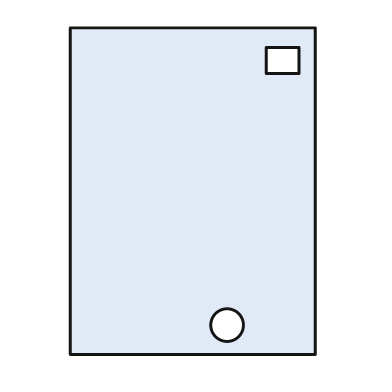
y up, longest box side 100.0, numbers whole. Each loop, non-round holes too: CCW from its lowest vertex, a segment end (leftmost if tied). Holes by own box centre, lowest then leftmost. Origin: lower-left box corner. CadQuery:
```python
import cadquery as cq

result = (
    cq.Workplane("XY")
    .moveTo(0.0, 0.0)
    .lineTo(75.0, 0.0)
    .lineTo(75.0, 100.0)
    .lineTo(0.0, 100.0)
    .close()
    .moveTo(48.0, 9.0)
    .circle(5.0)
    .moveTo(60.0, 86.0)
    .lineTo(70.0, 86.0)
    .lineTo(70.0, 94.0)
    .lineTo(60.0, 94.0)
    .close()
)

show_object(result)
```